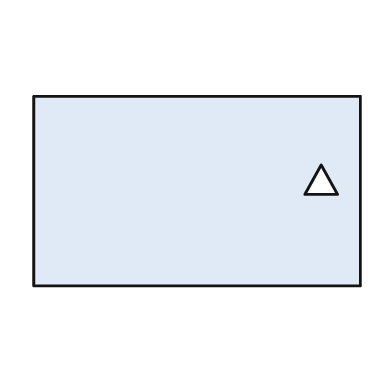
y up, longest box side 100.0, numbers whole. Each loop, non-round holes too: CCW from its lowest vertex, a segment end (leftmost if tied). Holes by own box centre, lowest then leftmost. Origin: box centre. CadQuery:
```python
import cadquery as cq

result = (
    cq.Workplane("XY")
    .moveTo(-50.0, -29.0)
    .lineTo(50.0, -29.0)
    .lineTo(50.0, 29.0)
    .lineTo(-50.0, 29.0)
    .close()
    .moveTo(33.0, -1.0)
    .lineTo(43.0, -1.0)
    .lineTo(38.0, 8.0)
    .close()
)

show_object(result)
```